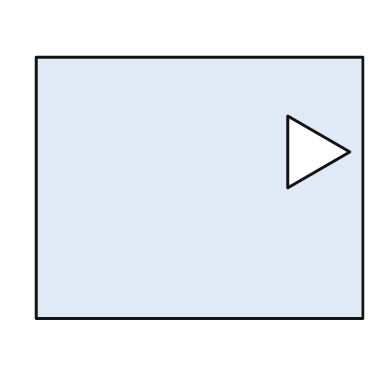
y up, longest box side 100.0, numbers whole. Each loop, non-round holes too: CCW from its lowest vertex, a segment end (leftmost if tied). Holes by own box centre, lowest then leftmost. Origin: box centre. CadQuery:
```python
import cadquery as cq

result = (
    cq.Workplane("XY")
    .moveTo(-50.0, -40.0)
    .lineTo(50.0, -40.0)
    .lineTo(50.0, 40.0)
    .lineTo(-50.0, 40.0)
    .close()
    .moveTo(27.0, 0.0)
    .lineTo(46.0, 11.0)
    .lineTo(27.0, 22.0)
    .close()
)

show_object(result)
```